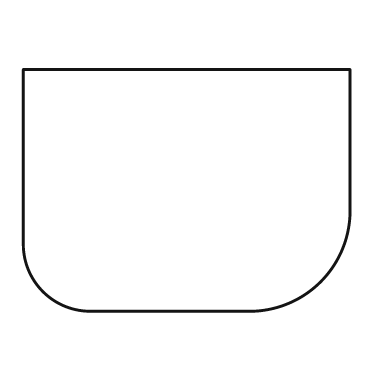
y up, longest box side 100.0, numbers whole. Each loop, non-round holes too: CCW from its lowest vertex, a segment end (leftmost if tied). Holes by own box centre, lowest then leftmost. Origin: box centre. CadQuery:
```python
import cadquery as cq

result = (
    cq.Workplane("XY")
    .moveTo(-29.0, -37.0)
    .lineTo(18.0, -37.0)
    .threePointArc((41.0, -28.0), (50.0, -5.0))
    .lineTo(50.0, 37.0)
    .lineTo(-50.0, 37.0)
    .lineTo(-50.0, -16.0)
    .threePointArc((-44.0, -31.0), (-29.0, -37.0))
    .close()
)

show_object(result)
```